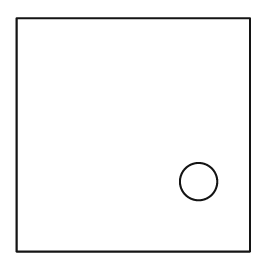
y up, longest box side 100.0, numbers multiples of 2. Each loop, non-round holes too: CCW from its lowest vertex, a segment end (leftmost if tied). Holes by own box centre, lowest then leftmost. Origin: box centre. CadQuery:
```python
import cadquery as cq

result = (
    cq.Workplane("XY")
    .moveTo(-50.0, -50.0)
    .lineTo(50.0, -50.0)
    .lineTo(50.0, 50.0)
    .lineTo(-50.0, 50.0)
    .close()
    .moveTo(28.0, -20.0)
    .circle(8.0)
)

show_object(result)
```